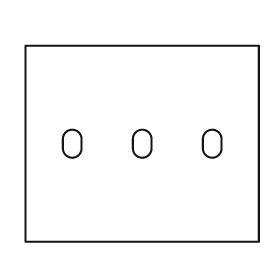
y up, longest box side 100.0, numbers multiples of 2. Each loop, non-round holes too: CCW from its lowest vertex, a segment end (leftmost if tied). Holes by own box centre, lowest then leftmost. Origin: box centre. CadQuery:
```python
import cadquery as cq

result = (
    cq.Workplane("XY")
    .moveTo(-50.0, -42.0)
    .lineTo(50.0, -42.0)
    .lineTo(50.0, 42.0)
    .lineTo(-50.0, 42.0)
    .close()
    .moveTo(-34.0, -2.0)
    .threePointArc((-30.0, -6.0), (-26.0, -2.0))
    .lineTo(-26.0, 2.0)
    .threePointArc((-30.0, 6.0), (-34.0, 2.0))
    .close()
    .moveTo(-4.0, -2.0)
    .threePointArc((0.0, -6.0), (4.0, -2.0))
    .lineTo(4.0, 2.0)
    .threePointArc((0.0, 6.0), (-4.0, 2.0))
    .close()
    .moveTo(26.0, -2.0)
    .threePointArc((30.0, -6.0), (34.0, -2.0))
    .lineTo(34.0, 2.0)
    .threePointArc((30.0, 6.0), (26.0, 2.0))
    .close()
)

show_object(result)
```